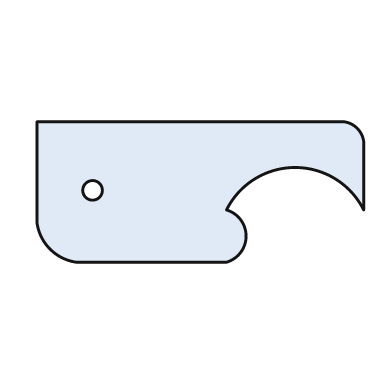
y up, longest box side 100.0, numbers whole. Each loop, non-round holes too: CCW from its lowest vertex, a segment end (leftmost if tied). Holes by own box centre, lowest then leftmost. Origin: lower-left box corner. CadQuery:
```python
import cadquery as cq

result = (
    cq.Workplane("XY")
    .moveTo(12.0, 0.0)
    .lineTo(58.0, 0.0)
    .threePointArc((64.0, 8.0), (58.0, 16.0))
    .threePointArc((79.0, 29.0), (100.0, 16.0))
    .lineTo(100.0, 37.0)
    .threePointArc((98.0, 41.0), (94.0, 43.0))
    .lineTo(0.0, 43.0)
    .lineTo(0.0, 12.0)
    .threePointArc((4.0, 4.0), (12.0, 0.0))
    .close()
    .moveTo(17.0, 22.0)
    .circle(3.0)
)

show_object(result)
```